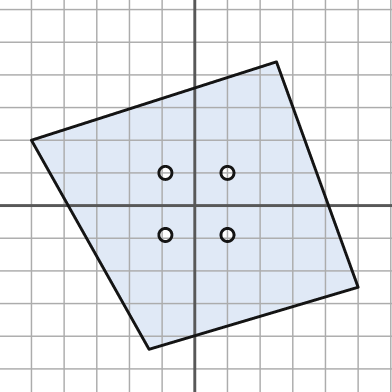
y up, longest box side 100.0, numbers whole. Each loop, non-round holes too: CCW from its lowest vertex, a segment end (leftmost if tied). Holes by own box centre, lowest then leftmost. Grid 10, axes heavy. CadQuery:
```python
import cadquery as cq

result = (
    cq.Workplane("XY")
    .moveTo(-14.0, -44.0)
    .lineTo(50.0, -25.0)
    .lineTo(25.0, 44.0)
    .lineTo(-50.0, 20.0)
    .close()
    .moveTo(-9.0, -9.0)
    .circle(2.0)
    .moveTo(10.0, -9.0)
    .circle(2.0)
    .moveTo(-9.0, 10.0)
    .circle(2.0)
    .moveTo(10.0, 10.0)
    .circle(2.0)
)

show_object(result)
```